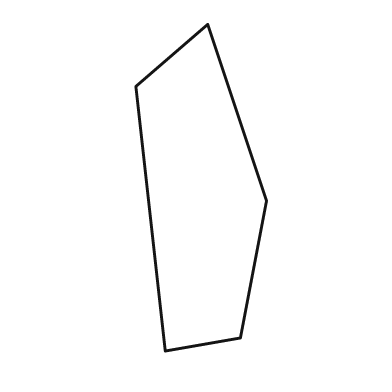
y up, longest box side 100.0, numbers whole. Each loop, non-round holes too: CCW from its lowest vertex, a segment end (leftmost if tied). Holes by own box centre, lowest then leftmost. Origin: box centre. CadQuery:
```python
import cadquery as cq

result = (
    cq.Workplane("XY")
    .moveTo(-11.0, -50.0)
    .lineTo(12.0, -46.0)
    .lineTo(20.0, -4.0)
    .lineTo(2.0, 50.0)
    .lineTo(-20.0, 31.0)
    .close()
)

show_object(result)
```